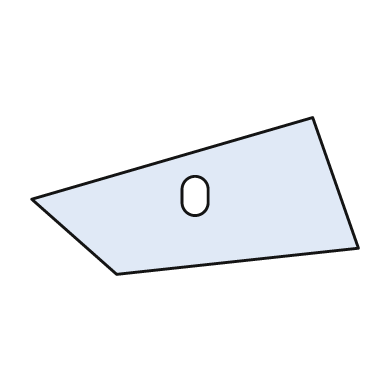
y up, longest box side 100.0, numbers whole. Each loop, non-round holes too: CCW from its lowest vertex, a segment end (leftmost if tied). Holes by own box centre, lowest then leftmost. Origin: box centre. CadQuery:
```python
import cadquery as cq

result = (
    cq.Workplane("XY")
    .moveTo(-24.0, -24.0)
    .lineTo(50.0, -16.0)
    .lineTo(36.0, 24.0)
    .lineTo(-50.0, -1.0)
    .close()
    .moveTo(-4.0, -2.0)
    .threePointArc((0.0, -6.0), (4.0, -2.0))
    .lineTo(4.0, 2.0)
    .threePointArc((0.0, 6.0), (-4.0, 2.0))
    .close()
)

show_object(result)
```